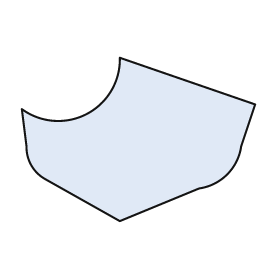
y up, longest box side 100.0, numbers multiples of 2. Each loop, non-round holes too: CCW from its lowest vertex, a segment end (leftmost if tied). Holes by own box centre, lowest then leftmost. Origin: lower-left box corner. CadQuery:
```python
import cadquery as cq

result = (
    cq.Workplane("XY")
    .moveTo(42.0, 0.0)
    .lineTo(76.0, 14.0)
    .threePointArc((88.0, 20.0), (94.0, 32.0))
    .lineTo(100.0, 50.0)
    .lineTo(42.0, 70.0)
    .threePointArc((28.0, 46.0), (0.0, 48.0))
    .lineTo(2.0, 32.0)
    .threePointArc((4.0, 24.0), (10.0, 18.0))
    .close()
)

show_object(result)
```